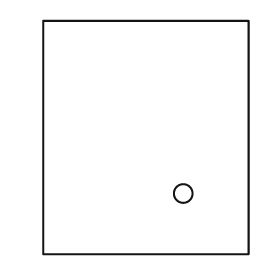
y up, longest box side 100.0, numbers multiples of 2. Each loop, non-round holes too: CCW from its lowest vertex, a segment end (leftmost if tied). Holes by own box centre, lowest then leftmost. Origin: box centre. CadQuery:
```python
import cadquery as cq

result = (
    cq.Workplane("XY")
    .moveTo(-44.0, -50.0)
    .lineTo(44.0, -50.0)
    .lineTo(44.0, 50.0)
    .lineTo(-44.0, 50.0)
    .close()
    .moveTo(16.0, -24.0)
    .circle(4.0)
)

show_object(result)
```